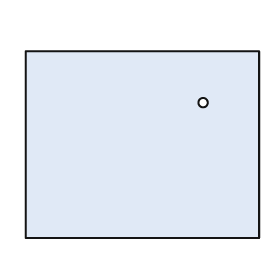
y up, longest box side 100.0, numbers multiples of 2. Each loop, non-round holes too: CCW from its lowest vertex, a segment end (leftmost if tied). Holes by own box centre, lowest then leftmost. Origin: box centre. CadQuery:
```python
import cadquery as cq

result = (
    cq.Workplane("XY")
    .moveTo(-50.0, -40.0)
    .lineTo(50.0, -40.0)
    .lineTo(50.0, 40.0)
    .lineTo(-50.0, 40.0)
    .close()
    .moveTo(26.0, 18.0)
    .circle(2.0)
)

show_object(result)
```